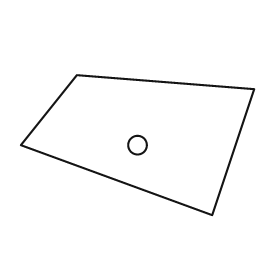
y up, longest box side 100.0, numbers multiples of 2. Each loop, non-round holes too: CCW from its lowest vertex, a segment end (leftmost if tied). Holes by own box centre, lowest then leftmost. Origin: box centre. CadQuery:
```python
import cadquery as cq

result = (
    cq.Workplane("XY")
    .moveTo(32.0, -30.0)
    .lineTo(50.0, 24.0)
    .lineTo(-26.0, 30.0)
    .lineTo(-50.0, 0.0)
    .close()
    .moveTo(0.0, 0.0)
    .circle(4.0)
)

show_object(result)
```